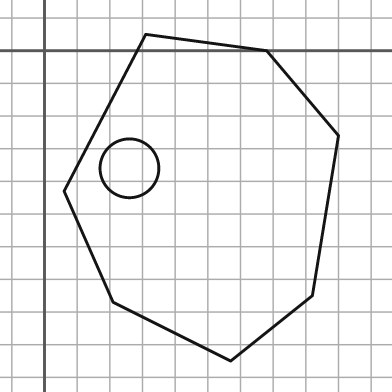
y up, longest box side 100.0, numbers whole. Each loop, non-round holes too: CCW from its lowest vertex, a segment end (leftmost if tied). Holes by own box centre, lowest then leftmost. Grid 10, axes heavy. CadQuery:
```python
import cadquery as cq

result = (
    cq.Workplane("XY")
    .moveTo(57.0, -95.0)
    .lineTo(82.0, -75.0)
    .lineTo(90.0, -26.0)
    .lineTo(68.0, 0.0)
    .lineTo(31.0, 5.0)
    .lineTo(6.0, -43.0)
    .lineTo(21.0, -77.0)
    .close()
    .moveTo(26.0, -36.0)
    .circle(9.0)
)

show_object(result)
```